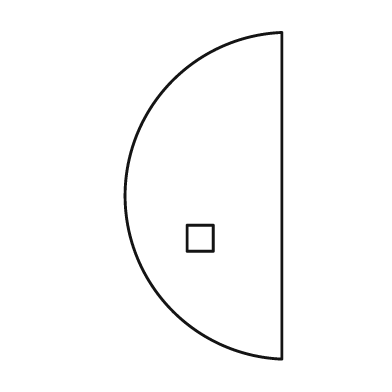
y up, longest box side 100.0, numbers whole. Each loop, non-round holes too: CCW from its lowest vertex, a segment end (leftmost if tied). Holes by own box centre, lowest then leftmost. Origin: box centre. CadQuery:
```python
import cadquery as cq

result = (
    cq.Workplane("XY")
    .moveTo(24.0, -50.0)
    .lineTo(24.0, 50.0)
    .threePointArc((-24.0, 0.0), (24.0, -50.0))
    .close()
    .moveTo(-5.0, -17.0)
    .lineTo(3.0, -17.0)
    .lineTo(3.0, -9.0)
    .lineTo(-5.0, -9.0)
    .close()
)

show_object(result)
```